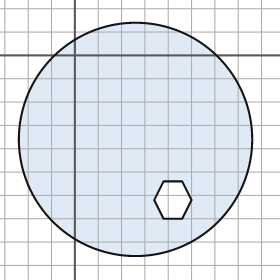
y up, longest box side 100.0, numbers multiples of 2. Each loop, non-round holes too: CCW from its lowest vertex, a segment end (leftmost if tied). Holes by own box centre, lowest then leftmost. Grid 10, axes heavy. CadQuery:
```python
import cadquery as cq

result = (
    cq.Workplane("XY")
    .moveTo(26.0, -36.0)
    .circle(50.0)
    .moveTo(38.0, -70.0)
    .lineTo(46.0, -70.0)
    .lineTo(50.0, -62.0)
    .lineTo(46.0, -54.0)
    .lineTo(38.0, -54.0)
    .lineTo(34.0, -62.0)
    .close()
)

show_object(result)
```